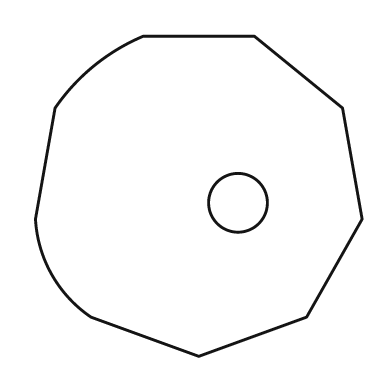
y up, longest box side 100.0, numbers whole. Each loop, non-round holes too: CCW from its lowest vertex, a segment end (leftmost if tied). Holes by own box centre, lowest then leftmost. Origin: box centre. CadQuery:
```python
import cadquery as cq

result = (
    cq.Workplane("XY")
    .moveTo(0.0, -49.0)
    .lineTo(33.0, -37.0)
    .lineTo(50.0, -7.0)
    .lineTo(44.0, 27.0)
    .lineTo(17.0, 49.0)
    .lineTo(-17.0, 49.0)
    .threePointArc((-32.0, 40.0), (-44.0, 27.0))
    .lineTo(-50.0, -7.0)
    .threePointArc((-45.0, -24.0), (-33.0, -37.0))
    .close()
    .moveTo(12.0, -2.0)
    .circle(9.0)
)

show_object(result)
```